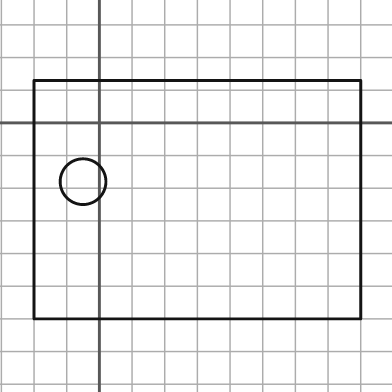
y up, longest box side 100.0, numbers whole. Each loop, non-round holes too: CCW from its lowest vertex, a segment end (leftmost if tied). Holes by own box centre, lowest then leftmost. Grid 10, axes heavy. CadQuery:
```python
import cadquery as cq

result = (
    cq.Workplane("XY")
    .moveTo(-20.0, -60.0)
    .lineTo(80.0, -60.0)
    .lineTo(80.0, 13.0)
    .lineTo(-20.0, 13.0)
    .close()
    .moveTo(-5.0, -18.0)
    .circle(7.0)
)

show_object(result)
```